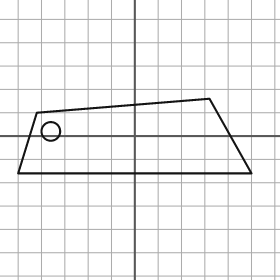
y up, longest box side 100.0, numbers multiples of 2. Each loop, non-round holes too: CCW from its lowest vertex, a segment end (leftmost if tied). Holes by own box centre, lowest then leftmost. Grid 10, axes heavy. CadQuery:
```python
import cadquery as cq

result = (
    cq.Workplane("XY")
    .moveTo(-50.0, -16.0)
    .lineTo(50.0, -16.0)
    .lineTo(32.0, 16.0)
    .lineTo(-42.0, 10.0)
    .close()
    .moveTo(-36.0, 2.0)
    .circle(4.0)
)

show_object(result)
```